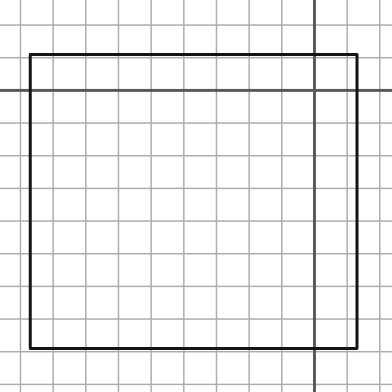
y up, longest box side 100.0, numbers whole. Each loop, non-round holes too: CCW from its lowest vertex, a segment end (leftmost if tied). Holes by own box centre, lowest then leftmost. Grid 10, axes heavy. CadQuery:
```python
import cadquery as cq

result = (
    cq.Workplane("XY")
    .moveTo(-87.0, -79.0)
    .lineTo(13.0, -79.0)
    .lineTo(13.0, 11.0)
    .lineTo(-87.0, 11.0)
    .close()
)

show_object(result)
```